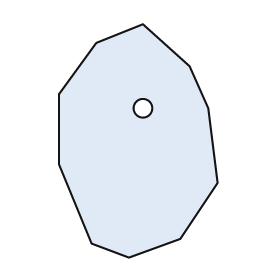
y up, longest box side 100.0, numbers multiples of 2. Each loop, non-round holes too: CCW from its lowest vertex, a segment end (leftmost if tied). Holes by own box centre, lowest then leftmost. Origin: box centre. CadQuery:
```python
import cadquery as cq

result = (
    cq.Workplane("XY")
    .moveTo(-4.0, -50.0)
    .lineTo(18.0, -42.0)
    .lineTo(34.0, -18.0)
    .lineTo(30.0, 14.0)
    .lineTo(22.0, 32.0)
    .lineTo(2.0, 50.0)
    .lineTo(-18.0, 42.0)
    .lineTo(-34.0, 20.0)
    .lineTo(-34.0, -10.0)
    .lineTo(-20.0, -44.0)
    .close()
    .moveTo(2.0, 14.0)
    .circle(4.0)
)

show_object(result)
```